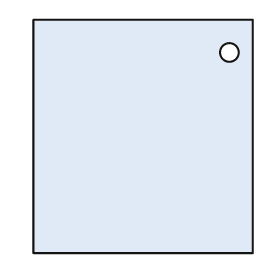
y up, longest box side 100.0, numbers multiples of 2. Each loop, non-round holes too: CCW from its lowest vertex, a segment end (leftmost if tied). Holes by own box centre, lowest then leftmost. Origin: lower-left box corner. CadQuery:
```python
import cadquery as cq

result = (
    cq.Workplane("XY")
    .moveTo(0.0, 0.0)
    .lineTo(94.0, 0.0)
    .lineTo(94.0, 100.0)
    .lineTo(0.0, 100.0)
    .close()
    .moveTo(84.0, 86.0)
    .circle(4.0)
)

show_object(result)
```